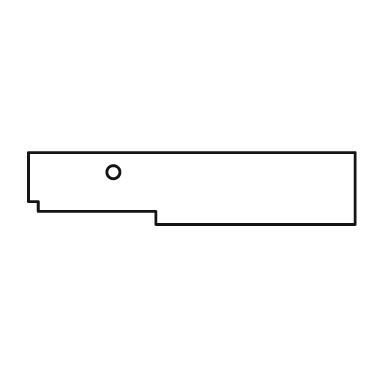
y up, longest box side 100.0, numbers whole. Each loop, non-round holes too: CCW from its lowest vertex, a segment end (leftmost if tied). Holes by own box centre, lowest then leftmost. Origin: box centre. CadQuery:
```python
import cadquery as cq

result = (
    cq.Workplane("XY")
    .moveTo(-11.0, -11.0)
    .lineTo(50.0, -11.0)
    .lineTo(50.0, 11.0)
    .lineTo(-50.0, 11.0)
    .lineTo(-50.0, -4.0)
    .lineTo(-47.0, -4.0)
    .lineTo(-47.0, -7.0)
    .lineTo(-11.0, -7.0)
    .close()
    .moveTo(-24.0, 5.0)
    .circle(2.0)
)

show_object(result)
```